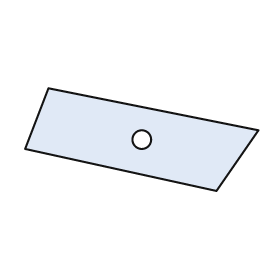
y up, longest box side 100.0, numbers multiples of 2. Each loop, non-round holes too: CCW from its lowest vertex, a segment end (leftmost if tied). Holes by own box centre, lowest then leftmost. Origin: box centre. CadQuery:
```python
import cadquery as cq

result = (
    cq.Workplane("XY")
    .moveTo(32.0, -22.0)
    .lineTo(50.0, 4.0)
    .lineTo(-40.0, 22.0)
    .lineTo(-50.0, -4.0)
    .close()
    .moveTo(0.0, 0.0)
    .circle(4.0)
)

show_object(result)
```